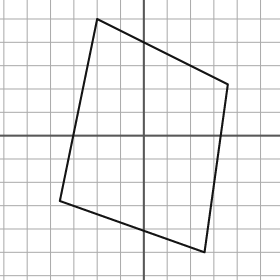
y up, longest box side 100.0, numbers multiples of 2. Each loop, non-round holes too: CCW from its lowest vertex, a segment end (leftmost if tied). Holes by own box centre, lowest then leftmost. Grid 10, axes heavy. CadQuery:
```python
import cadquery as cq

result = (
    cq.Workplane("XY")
    .moveTo(26.0, -50.0)
    .lineTo(36.0, 22.0)
    .lineTo(-20.0, 50.0)
    .lineTo(-36.0, -28.0)
    .close()
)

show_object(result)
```